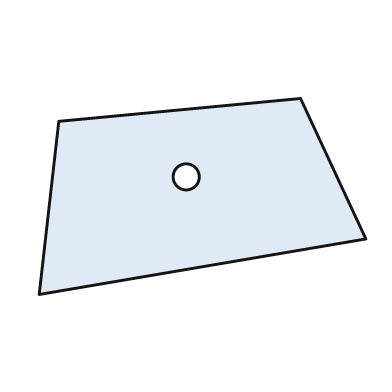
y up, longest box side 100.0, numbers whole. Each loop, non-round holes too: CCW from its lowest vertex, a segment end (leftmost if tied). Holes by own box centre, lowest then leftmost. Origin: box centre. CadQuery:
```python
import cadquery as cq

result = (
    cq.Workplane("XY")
    .moveTo(-50.0, -30.0)
    .lineTo(50.0, -13.0)
    .lineTo(30.0, 30.0)
    .lineTo(-44.0, 23.0)
    .close()
    .moveTo(-5.0, 6.0)
    .circle(4.0)
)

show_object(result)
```